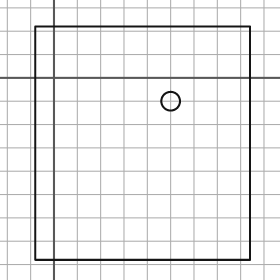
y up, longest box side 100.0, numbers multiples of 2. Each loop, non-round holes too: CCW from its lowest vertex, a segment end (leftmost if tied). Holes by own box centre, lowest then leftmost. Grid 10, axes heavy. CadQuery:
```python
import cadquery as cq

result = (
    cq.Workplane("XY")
    .moveTo(-8.0, -78.0)
    .lineTo(84.0, -78.0)
    .lineTo(84.0, 22.0)
    .lineTo(-8.0, 22.0)
    .close()
    .moveTo(50.0, -10.0)
    .circle(4.0)
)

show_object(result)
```